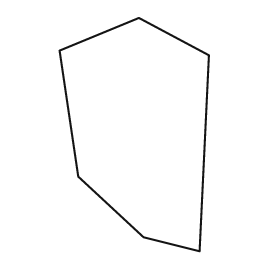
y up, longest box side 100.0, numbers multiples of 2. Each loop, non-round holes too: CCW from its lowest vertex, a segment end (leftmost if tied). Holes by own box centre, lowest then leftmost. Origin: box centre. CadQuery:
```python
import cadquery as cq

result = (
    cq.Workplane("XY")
    .moveTo(28.0, -50.0)
    .lineTo(32.0, 34.0)
    .lineTo(2.0, 50.0)
    .lineTo(-32.0, 36.0)
    .lineTo(-24.0, -18.0)
    .lineTo(4.0, -44.0)
    .close()
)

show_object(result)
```